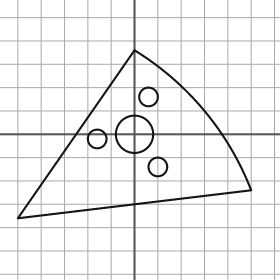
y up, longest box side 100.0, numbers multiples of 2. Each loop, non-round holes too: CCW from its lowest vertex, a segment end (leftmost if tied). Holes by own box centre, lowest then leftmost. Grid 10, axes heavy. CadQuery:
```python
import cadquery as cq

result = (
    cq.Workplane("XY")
    .moveTo(-50.0, -36.0)
    .lineTo(50.0, -24.0)
    .threePointArc((30.0, 10.0), (0.0, 36.0))
    .close()
    .moveTo(10.0, -14.0)
    .circle(4.0)
    .moveTo(-16.0, -2.0)
    .circle(4.0)
    .moveTo(0.0, 0.0)
    .circle(8.0)
    .moveTo(6.0, 16.0)
    .circle(4.0)
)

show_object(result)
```